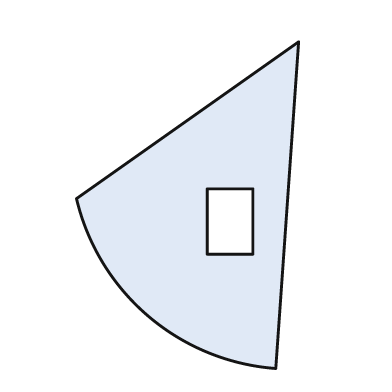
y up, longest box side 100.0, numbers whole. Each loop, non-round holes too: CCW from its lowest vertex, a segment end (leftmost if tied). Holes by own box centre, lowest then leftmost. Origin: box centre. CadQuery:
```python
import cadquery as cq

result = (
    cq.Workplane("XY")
    .moveTo(27.0, -50.0)
    .lineTo(34.0, 50.0)
    .lineTo(-34.0, 2.0)
    .threePointArc((-12.0, -34.0), (27.0, -50.0))
    .close()
    .moveTo(6.0, -15.0)
    .lineTo(20.0, -15.0)
    .lineTo(20.0, 5.0)
    .lineTo(6.0, 5.0)
    .close()
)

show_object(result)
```